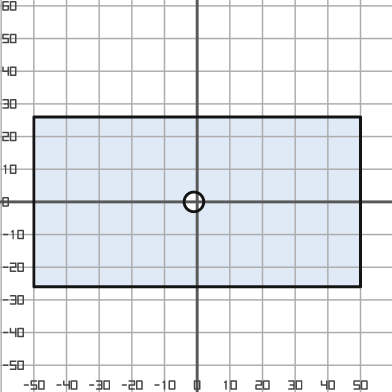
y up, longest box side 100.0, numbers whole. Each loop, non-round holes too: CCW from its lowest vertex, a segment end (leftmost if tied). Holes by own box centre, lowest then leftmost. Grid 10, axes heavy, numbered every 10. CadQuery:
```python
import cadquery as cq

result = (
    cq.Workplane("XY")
    .moveTo(-50.0, -26.0)
    .lineTo(50.0, -26.0)
    .lineTo(50.0, 26.0)
    .lineTo(-50.0, 26.0)
    .close()
    .moveTo(-1.0, 0.0)
    .circle(3.0)
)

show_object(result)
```